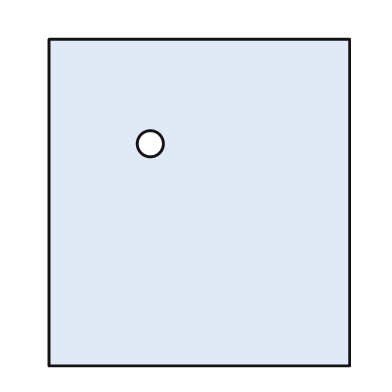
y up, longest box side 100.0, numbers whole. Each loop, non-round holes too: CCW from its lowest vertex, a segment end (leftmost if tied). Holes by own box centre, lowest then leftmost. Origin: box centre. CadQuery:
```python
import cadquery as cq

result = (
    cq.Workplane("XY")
    .moveTo(-46.0, -50.0)
    .lineTo(46.0, -50.0)
    .lineTo(46.0, 50.0)
    .lineTo(-46.0, 50.0)
    .close()
    .moveTo(-15.0, 18.0)
    .circle(4.0)
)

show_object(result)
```